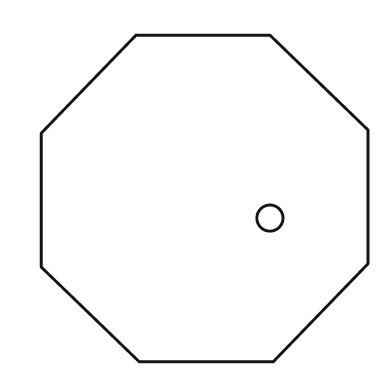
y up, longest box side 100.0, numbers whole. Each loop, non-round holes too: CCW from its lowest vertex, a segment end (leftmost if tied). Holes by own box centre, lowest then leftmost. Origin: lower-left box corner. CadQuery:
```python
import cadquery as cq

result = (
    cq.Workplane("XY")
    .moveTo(30.0, 0.0)
    .lineTo(71.0, 0.0)
    .lineTo(100.0, 30.0)
    .lineTo(100.0, 71.0)
    .lineTo(70.0, 100.0)
    .lineTo(29.0, 100.0)
    .lineTo(0.0, 70.0)
    .lineTo(0.0, 29.0)
    .close()
    .moveTo(70.0, 44.0)
    .circle(4.0)
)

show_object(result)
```